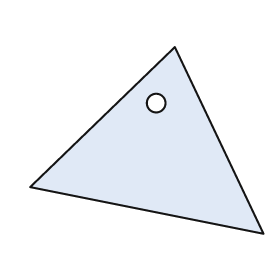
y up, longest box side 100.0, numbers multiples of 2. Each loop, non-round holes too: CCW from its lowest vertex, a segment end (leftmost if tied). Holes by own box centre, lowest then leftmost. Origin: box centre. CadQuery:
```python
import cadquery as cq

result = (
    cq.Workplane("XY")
    .moveTo(50.0, -40.0)
    .lineTo(12.0, 40.0)
    .lineTo(-50.0, -20.0)
    .close()
    .moveTo(4.0, 16.0)
    .circle(4.0)
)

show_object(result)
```